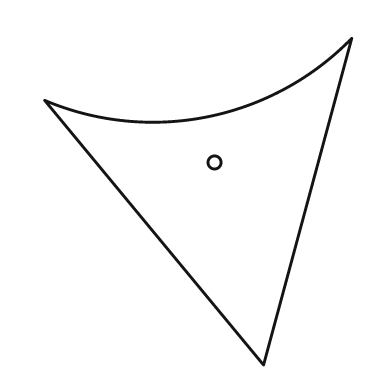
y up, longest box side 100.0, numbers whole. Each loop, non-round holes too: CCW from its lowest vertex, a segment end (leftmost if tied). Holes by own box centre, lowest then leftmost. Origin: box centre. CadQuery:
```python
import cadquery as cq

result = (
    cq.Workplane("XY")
    .moveTo(20.0, -50.0)
    .lineTo(47.0, 50.0)
    .threePointArc((3.0, 26.0), (-47.0, 31.0))
    .close()
    .moveTo(5.0, 12.0)
    .circle(2.0)
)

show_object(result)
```